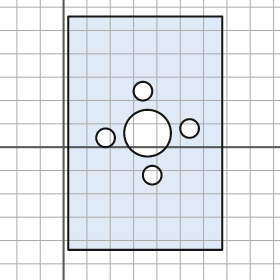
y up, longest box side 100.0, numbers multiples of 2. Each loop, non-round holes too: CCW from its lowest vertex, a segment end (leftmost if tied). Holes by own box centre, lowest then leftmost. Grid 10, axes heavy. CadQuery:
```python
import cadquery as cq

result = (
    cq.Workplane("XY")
    .moveTo(2.0, -44.0)
    .lineTo(68.0, -44.0)
    .lineTo(68.0, 56.0)
    .lineTo(2.0, 56.0)
    .close()
    .moveTo(38.0, -12.0)
    .circle(4.0)
    .moveTo(18.0, 4.0)
    .circle(4.0)
    .moveTo(36.0, 6.0)
    .circle(10.0)
    .moveTo(54.0, 8.0)
    .circle(4.0)
    .moveTo(34.0, 24.0)
    .circle(4.0)
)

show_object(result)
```